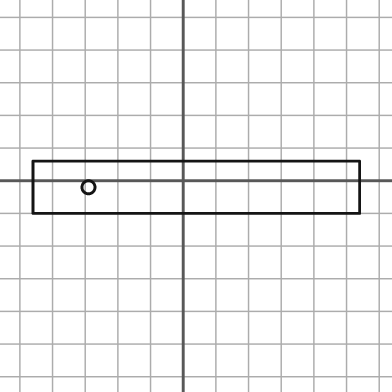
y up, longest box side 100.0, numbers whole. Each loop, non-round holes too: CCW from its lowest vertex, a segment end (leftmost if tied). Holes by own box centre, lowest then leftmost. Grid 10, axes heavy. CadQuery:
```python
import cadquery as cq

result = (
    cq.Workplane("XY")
    .moveTo(-46.0, -10.0)
    .lineTo(54.0, -10.0)
    .lineTo(54.0, 6.0)
    .lineTo(-46.0, 6.0)
    .close()
    .moveTo(-29.0, -2.0)
    .circle(2.0)
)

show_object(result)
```